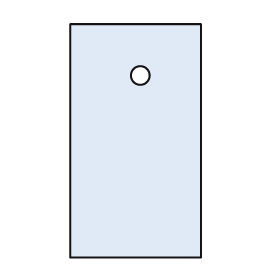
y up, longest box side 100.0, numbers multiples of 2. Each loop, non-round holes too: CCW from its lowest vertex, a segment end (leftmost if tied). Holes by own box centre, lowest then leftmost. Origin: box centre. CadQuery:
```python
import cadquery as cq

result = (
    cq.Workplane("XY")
    .moveTo(-28.0, -50.0)
    .lineTo(28.0, -50.0)
    .lineTo(28.0, 50.0)
    .lineTo(-28.0, 50.0)
    .close()
    .moveTo(2.0, 28.0)
    .circle(4.0)
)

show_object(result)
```